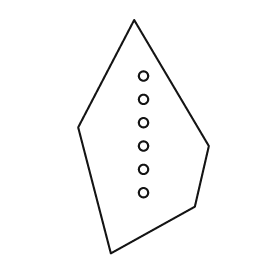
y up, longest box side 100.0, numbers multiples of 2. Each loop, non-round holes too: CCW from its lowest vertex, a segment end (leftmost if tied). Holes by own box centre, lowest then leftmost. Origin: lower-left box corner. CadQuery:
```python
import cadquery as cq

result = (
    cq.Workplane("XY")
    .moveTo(14.0, 0.0)
    .lineTo(50.0, 20.0)
    .lineTo(56.0, 46.0)
    .lineTo(24.0, 100.0)
    .lineTo(0.0, 54.0)
    .close()
    .moveTo(28.0, 26.0)
    .circle(2.0)
    .moveTo(28.0, 36.0)
    .circle(2.0)
    .moveTo(28.0, 46.0)
    .circle(2.0)
    .moveTo(28.0, 56.0)
    .circle(2.0)
    .moveTo(28.0, 66.0)
    .circle(2.0)
    .moveTo(28.0, 76.0)
    .circle(2.0)
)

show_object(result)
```